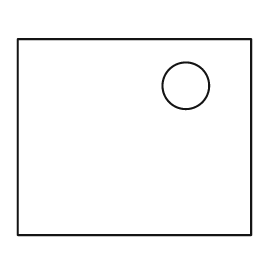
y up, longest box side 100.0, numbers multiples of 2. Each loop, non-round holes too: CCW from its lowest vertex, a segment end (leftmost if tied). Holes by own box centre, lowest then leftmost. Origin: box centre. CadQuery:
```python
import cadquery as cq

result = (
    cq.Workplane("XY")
    .moveTo(-50.0, -42.0)
    .lineTo(50.0, -42.0)
    .lineTo(50.0, 42.0)
    .lineTo(-50.0, 42.0)
    .close()
    .moveTo(22.0, 22.0)
    .circle(10.0)
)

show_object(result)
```